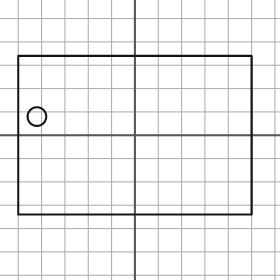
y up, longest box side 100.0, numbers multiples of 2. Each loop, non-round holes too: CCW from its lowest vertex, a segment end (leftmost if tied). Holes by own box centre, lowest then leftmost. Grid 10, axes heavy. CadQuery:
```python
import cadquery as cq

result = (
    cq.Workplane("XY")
    .moveTo(-50.0, -34.0)
    .lineTo(50.0, -34.0)
    .lineTo(50.0, 34.0)
    .lineTo(-50.0, 34.0)
    .close()
    .moveTo(-42.0, 8.0)
    .circle(4.0)
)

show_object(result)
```